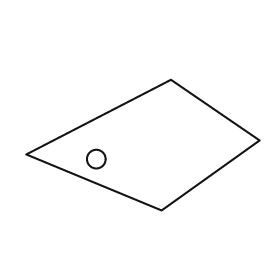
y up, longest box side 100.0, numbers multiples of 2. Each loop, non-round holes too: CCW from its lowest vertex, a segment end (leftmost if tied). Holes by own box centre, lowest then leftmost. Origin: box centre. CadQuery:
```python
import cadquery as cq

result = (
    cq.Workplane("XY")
    .moveTo(8.0, -28.0)
    .lineTo(50.0, 2.0)
    .lineTo(12.0, 28.0)
    .lineTo(-50.0, -4.0)
    .close()
    .moveTo(-20.0, -6.0)
    .circle(4.0)
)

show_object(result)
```